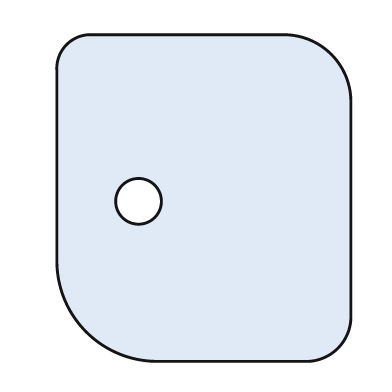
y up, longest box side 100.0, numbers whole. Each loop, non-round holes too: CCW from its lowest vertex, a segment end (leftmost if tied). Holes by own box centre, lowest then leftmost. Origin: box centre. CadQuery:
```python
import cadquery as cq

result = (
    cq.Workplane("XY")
    .moveTo(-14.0, -50.0)
    .lineTo(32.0, -50.0)
    .threePointArc((41.0, -46.0), (45.0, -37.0))
    .lineTo(45.0, 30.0)
    .threePointArc((39.0, 44.0), (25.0, 50.0))
    .lineTo(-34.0, 50.0)
    .threePointArc((-42.0, 47.0), (-45.0, 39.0))
    .lineTo(-45.0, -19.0)
    .threePointArc((-36.0, -41.0), (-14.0, -50.0))
    .close()
    .moveTo(-20.0, -1.0)
    .circle(7.0)
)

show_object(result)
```